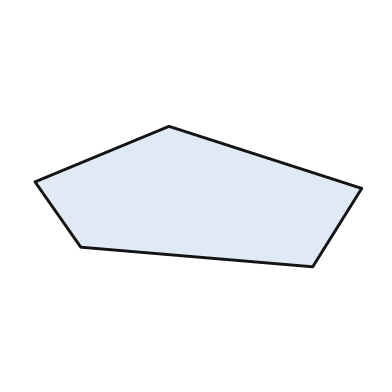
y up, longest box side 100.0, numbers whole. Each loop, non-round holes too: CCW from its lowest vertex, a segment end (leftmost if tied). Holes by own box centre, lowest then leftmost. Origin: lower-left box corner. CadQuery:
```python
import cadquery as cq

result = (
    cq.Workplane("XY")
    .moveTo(85.0, 0.0)
    .lineTo(100.0, 24.0)
    .lineTo(41.0, 43.0)
    .lineTo(0.0, 26.0)
    .lineTo(14.0, 6.0)
    .close()
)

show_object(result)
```